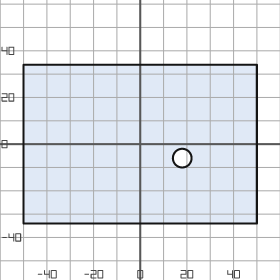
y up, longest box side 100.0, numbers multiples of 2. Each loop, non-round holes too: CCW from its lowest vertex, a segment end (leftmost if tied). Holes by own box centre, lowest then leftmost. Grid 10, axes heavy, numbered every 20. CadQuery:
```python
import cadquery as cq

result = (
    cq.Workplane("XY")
    .moveTo(-50.0, -34.0)
    .lineTo(50.0, -34.0)
    .lineTo(50.0, 34.0)
    .lineTo(-50.0, 34.0)
    .close()
    .moveTo(18.0, -6.0)
    .circle(4.0)
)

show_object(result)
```